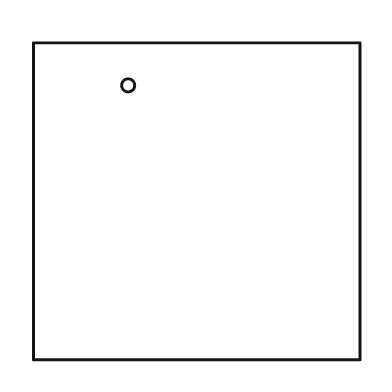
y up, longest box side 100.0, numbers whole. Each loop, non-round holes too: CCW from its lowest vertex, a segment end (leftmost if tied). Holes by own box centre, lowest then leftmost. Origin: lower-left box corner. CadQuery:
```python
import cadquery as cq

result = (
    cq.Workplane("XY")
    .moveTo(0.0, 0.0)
    .lineTo(100.0, 0.0)
    .lineTo(100.0, 97.0)
    .lineTo(0.0, 97.0)
    .close()
    .moveTo(29.0, 84.0)
    .circle(2.0)
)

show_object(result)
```